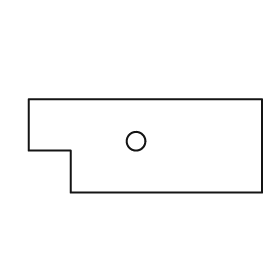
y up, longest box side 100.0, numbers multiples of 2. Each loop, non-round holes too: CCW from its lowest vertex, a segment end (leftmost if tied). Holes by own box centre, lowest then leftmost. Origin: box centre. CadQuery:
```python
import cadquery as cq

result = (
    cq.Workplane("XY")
    .moveTo(-32.0, -20.0)
    .lineTo(50.0, -20.0)
    .lineTo(50.0, 20.0)
    .lineTo(-50.0, 20.0)
    .lineTo(-50.0, -2.0)
    .lineTo(-32.0, -2.0)
    .close()
    .moveTo(-4.0, 2.0)
    .circle(4.0)
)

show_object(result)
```